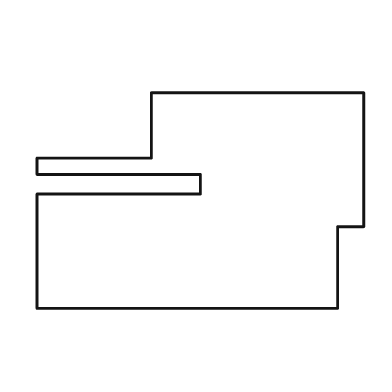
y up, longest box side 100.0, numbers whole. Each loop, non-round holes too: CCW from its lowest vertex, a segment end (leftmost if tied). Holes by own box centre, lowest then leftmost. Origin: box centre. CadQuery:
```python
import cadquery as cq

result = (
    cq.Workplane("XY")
    .moveTo(-50.0, -33.0)
    .lineTo(42.0, -33.0)
    .lineTo(42.0, -8.0)
    .lineTo(50.0, -8.0)
    .lineTo(50.0, 33.0)
    .lineTo(-15.0, 33.0)
    .lineTo(-15.0, 13.0)
    .lineTo(-50.0, 13.0)
    .lineTo(-50.0, 8.0)
    .lineTo(0.0, 8.0)
    .lineTo(0.0, 2.0)
    .lineTo(-50.0, 2.0)
    .close()
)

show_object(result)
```